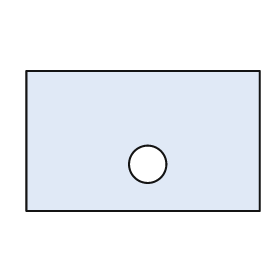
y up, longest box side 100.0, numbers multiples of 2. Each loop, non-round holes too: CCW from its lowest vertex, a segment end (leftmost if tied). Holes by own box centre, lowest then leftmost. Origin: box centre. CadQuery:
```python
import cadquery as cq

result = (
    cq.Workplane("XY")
    .moveTo(-50.0, -30.0)
    .lineTo(50.0, -30.0)
    .lineTo(50.0, 30.0)
    .lineTo(-50.0, 30.0)
    .close()
    .moveTo(2.0, -10.0)
    .circle(8.0)
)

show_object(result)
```